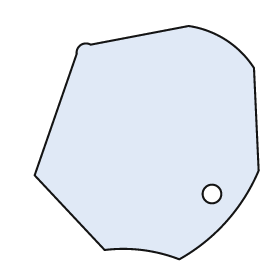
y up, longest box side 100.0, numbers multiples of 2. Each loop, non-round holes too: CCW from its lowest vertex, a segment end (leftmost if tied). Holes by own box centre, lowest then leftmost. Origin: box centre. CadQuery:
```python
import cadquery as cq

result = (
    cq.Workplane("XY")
    .moveTo(14.0, -50.0)
    .threePointArc((34.0, -34.0), (48.0, -12.0))
    .lineTo(46.0, 32.0)
    .threePointArc((34.0, 44.0), (18.0, 50.0))
    .lineTo(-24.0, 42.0)
    .threePointArc((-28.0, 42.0), (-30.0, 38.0))
    .lineTo(-48.0, -14.0)
    .lineTo(-18.0, -46.0)
    .threePointArc((-2.0, -46.0), (14.0, -50.0))
    .close()
    .moveTo(28.0, -22.0)
    .circle(4.0)
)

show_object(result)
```